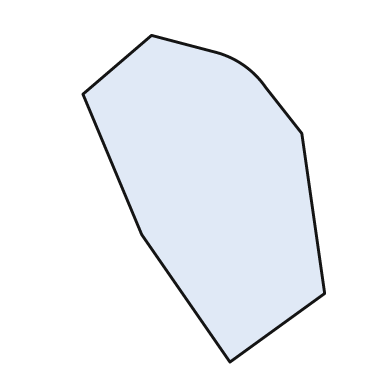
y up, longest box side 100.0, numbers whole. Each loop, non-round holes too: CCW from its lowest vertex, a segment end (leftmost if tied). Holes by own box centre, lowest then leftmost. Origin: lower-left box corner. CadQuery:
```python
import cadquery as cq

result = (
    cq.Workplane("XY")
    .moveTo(45.0, 0.0)
    .lineTo(74.0, 21.0)
    .lineTo(67.0, 70.0)
    .lineTo(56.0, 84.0)
    .threePointArc((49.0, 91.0), (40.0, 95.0))
    .lineTo(21.0, 100.0)
    .lineTo(0.0, 82.0)
    .lineTo(18.0, 39.0)
    .close()
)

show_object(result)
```